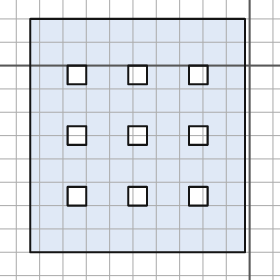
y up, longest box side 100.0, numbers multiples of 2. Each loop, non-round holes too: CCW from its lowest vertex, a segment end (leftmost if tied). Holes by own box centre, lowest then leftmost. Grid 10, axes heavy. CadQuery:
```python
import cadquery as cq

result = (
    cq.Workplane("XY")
    .moveTo(-94.0, -80.0)
    .lineTo(-2.0, -80.0)
    .lineTo(-2.0, 20.0)
    .lineTo(-94.0, 20.0)
    .close()
    .moveTo(-78.0, -60.0)
    .lineTo(-70.0, -60.0)
    .lineTo(-70.0, -52.0)
    .lineTo(-78.0, -52.0)
    .close()
    .moveTo(-52.0, -60.0)
    .lineTo(-44.0, -60.0)
    .lineTo(-44.0, -52.0)
    .lineTo(-52.0, -52.0)
    .close()
    .moveTo(-26.0, -60.0)
    .lineTo(-18.0, -60.0)
    .lineTo(-18.0, -52.0)
    .lineTo(-26.0, -52.0)
    .close()
    .moveTo(-78.0, -34.0)
    .lineTo(-70.0, -34.0)
    .lineTo(-70.0, -26.0)
    .lineTo(-78.0, -26.0)
    .close()
    .moveTo(-52.0, -34.0)
    .lineTo(-44.0, -34.0)
    .lineTo(-44.0, -26.0)
    .lineTo(-52.0, -26.0)
    .close()
    .moveTo(-26.0, -34.0)
    .lineTo(-18.0, -34.0)
    .lineTo(-18.0, -26.0)
    .lineTo(-26.0, -26.0)
    .close()
    .moveTo(-78.0, -8.0)
    .lineTo(-70.0, -8.0)
    .lineTo(-70.0, 0.0)
    .lineTo(-78.0, 0.0)
    .close()
    .moveTo(-52.0, -8.0)
    .lineTo(-44.0, -8.0)
    .lineTo(-44.0, 0.0)
    .lineTo(-52.0, 0.0)
    .close()
    .moveTo(-26.0, -8.0)
    .lineTo(-18.0, -8.0)
    .lineTo(-18.0, 0.0)
    .lineTo(-26.0, 0.0)
    .close()
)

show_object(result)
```